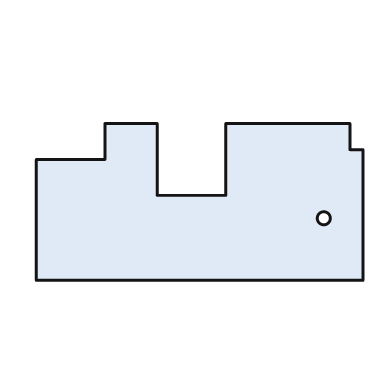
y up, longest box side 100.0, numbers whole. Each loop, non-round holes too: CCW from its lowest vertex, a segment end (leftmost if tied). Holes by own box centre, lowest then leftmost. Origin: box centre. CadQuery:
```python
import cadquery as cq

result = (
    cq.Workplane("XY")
    .moveTo(-50.0, -24.0)
    .lineTo(50.0, -24.0)
    .lineTo(50.0, 16.0)
    .lineTo(46.0, 16.0)
    .lineTo(46.0, 24.0)
    .lineTo(8.0, 24.0)
    .lineTo(8.0, 2.0)
    .lineTo(-13.0, 2.0)
    .lineTo(-13.0, 24.0)
    .lineTo(-29.0, 24.0)
    .lineTo(-29.0, 13.0)
    .lineTo(-50.0, 13.0)
    .close()
    .moveTo(38.0, -5.0)
    .circle(2.0)
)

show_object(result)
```